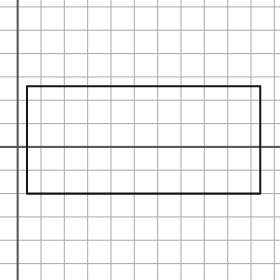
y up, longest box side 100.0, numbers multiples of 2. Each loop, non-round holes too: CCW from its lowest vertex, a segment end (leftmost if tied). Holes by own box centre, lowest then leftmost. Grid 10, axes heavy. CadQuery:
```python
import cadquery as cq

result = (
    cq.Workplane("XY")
    .moveTo(4.0, -20.0)
    .lineTo(104.0, -20.0)
    .lineTo(104.0, 26.0)
    .lineTo(4.0, 26.0)
    .close()
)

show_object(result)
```